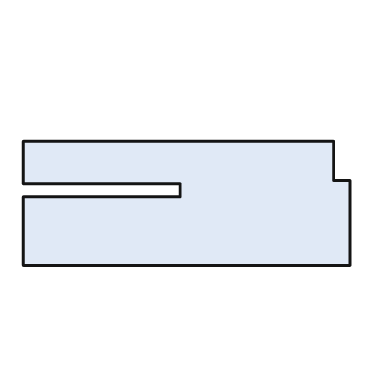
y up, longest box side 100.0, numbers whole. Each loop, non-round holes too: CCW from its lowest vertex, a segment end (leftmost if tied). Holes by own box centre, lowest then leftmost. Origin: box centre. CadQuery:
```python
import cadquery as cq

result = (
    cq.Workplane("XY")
    .moveTo(-50.0, -19.0)
    .lineTo(50.0, -19.0)
    .lineTo(50.0, 7.0)
    .lineTo(45.0, 7.0)
    .lineTo(45.0, 19.0)
    .lineTo(-50.0, 19.0)
    .lineTo(-50.0, 6.0)
    .lineTo(-2.0, 6.0)
    .lineTo(-2.0, 2.0)
    .lineTo(-50.0, 2.0)
    .close()
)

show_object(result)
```